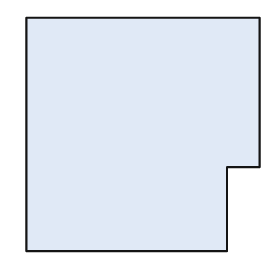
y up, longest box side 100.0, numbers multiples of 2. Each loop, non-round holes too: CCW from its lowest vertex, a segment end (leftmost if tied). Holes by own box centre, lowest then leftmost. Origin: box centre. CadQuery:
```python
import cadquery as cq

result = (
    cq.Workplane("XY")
    .moveTo(-50.0, -50.0)
    .lineTo(36.0, -50.0)
    .lineTo(36.0, -14.0)
    .lineTo(50.0, -14.0)
    .lineTo(50.0, 50.0)
    .lineTo(-50.0, 50.0)
    .close()
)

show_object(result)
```